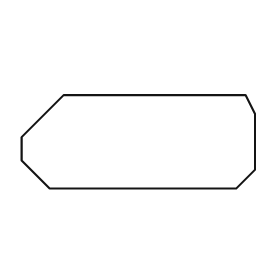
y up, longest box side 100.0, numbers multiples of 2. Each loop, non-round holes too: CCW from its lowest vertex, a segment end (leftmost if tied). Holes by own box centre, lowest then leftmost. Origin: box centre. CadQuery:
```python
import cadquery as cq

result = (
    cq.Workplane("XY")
    .moveTo(-38.0, -20.0)
    .lineTo(42.0, -20.0)
    .lineTo(50.0, -12.0)
    .lineTo(50.0, 12.0)
    .lineTo(46.0, 20.0)
    .lineTo(-32.0, 20.0)
    .lineTo(-50.0, 2.0)
    .lineTo(-50.0, -8.0)
    .close()
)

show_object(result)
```